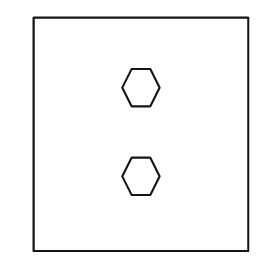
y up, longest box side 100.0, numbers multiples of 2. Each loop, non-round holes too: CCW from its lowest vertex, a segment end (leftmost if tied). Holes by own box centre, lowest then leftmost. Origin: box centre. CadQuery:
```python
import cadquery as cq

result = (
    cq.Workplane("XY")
    .moveTo(-46.0, -50.0)
    .lineTo(46.0, -50.0)
    .lineTo(46.0, 50.0)
    .lineTo(-46.0, 50.0)
    .close()
    .moveTo(-4.0, -26.0)
    .lineTo(4.0, -26.0)
    .lineTo(8.0, -18.0)
    .lineTo(4.0, -10.0)
    .lineTo(-4.0, -10.0)
    .lineTo(-8.0, -18.0)
    .close()
    .moveTo(-4.0, 12.0)
    .lineTo(4.0, 12.0)
    .lineTo(8.0, 20.0)
    .lineTo(4.0, 28.0)
    .lineTo(-4.0, 28.0)
    .lineTo(-8.0, 20.0)
    .close()
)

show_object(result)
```